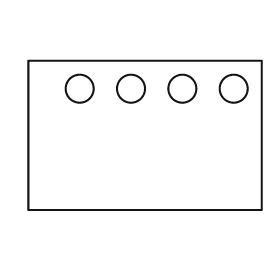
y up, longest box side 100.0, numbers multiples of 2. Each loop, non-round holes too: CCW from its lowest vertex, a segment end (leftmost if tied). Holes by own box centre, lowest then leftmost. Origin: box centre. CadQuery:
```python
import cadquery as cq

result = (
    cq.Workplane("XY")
    .moveTo(-50.0, -32.0)
    .lineTo(50.0, -32.0)
    .lineTo(50.0, 32.0)
    .lineTo(-50.0, 32.0)
    .close()
    .moveTo(-28.0, 20.0)
    .circle(6.0)
    .moveTo(-6.0, 20.0)
    .circle(6.0)
    .moveTo(16.0, 20.0)
    .circle(6.0)
    .moveTo(38.0, 20.0)
    .circle(6.0)
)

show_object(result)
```